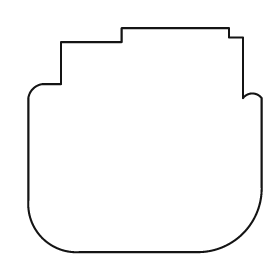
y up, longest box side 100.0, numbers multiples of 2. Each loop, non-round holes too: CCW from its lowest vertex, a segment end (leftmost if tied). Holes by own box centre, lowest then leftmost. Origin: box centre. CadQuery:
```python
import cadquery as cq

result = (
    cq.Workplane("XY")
    .moveTo(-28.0, -48.0)
    .lineTo(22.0, -48.0)
    .threePointArc((42.0, -40.0), (50.0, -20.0))
    .lineTo(50.0, 18.0)
    .threePointArc((46.0, 20.0), (42.0, 18.0))
    .lineTo(42.0, 44.0)
    .lineTo(36.0, 44.0)
    .lineTo(36.0, 48.0)
    .lineTo(-10.0, 48.0)
    .lineTo(-10.0, 42.0)
    .lineTo(-36.0, 42.0)
    .lineTo(-36.0, 24.0)
    .lineTo(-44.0, 24.0)
    .threePointArc((-48.0, 22.0), (-50.0, 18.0))
    .lineTo(-50.0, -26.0)
    .threePointArc((-44.0, -42.0), (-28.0, -48.0))
    .close()
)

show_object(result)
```